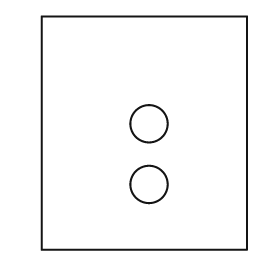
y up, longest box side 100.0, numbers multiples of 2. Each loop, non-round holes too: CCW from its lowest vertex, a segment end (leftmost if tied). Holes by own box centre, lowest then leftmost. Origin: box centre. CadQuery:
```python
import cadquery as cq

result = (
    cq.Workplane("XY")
    .moveTo(-44.0, -50.0)
    .lineTo(44.0, -50.0)
    .lineTo(44.0, 50.0)
    .lineTo(-44.0, 50.0)
    .close()
    .moveTo(2.0, -22.0)
    .circle(8.0)
    .moveTo(2.0, 4.0)
    .circle(8.0)
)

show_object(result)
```